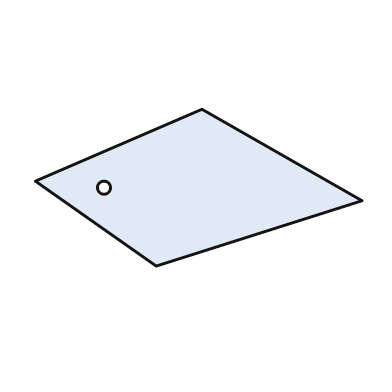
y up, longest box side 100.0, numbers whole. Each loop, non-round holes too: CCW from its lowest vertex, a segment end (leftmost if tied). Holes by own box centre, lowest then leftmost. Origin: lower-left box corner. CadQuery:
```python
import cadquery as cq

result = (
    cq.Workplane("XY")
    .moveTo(37.0, 0.0)
    .lineTo(100.0, 20.0)
    .lineTo(51.0, 48.0)
    .lineTo(0.0, 26.0)
    .close()
    .moveTo(21.0, 24.0)
    .circle(2.0)
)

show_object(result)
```